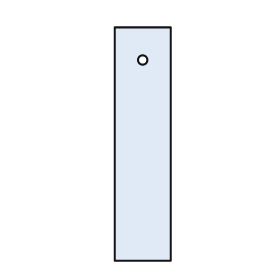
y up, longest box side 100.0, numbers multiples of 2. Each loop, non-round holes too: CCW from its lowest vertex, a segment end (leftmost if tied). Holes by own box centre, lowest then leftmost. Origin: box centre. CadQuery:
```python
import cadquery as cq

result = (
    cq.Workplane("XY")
    .moveTo(-12.0, -50.0)
    .lineTo(12.0, -50.0)
    .lineTo(12.0, 50.0)
    .lineTo(-12.0, 50.0)
    .close()
    .moveTo(0.0, 36.0)
    .circle(2.0)
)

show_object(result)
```